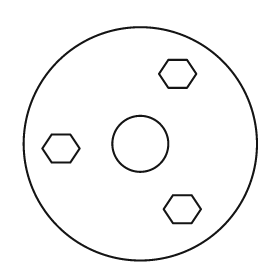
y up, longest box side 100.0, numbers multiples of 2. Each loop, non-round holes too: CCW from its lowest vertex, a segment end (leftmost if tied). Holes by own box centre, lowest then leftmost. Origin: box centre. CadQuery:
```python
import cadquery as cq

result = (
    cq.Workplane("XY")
    .moveTo(0.0, 0.0)
    .circle(50.0)
    .moveTo(14.0, -34.0)
    .lineTo(22.0, -34.0)
    .lineTo(26.0, -28.0)
    .lineTo(22.0, -22.0)
    .lineTo(14.0, -22.0)
    .lineTo(10.0, -28.0)
    .close()
    .moveTo(-38.0, -8.0)
    .lineTo(-30.0, -8.0)
    .lineTo(-26.0, -2.0)
    .lineTo(-30.0, 4.0)
    .lineTo(-38.0, 4.0)
    .lineTo(-42.0, -2.0)
    .close()
    .moveTo(0.0, 0.0)
    .circle(12.0)
    .moveTo(12.0, 24.0)
    .lineTo(20.0, 24.0)
    .lineTo(24.0, 30.0)
    .lineTo(20.0, 36.0)
    .lineTo(12.0, 36.0)
    .lineTo(8.0, 30.0)
    .close()
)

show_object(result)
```